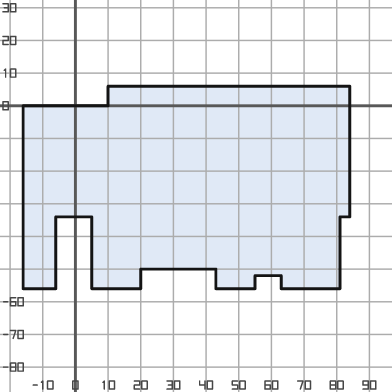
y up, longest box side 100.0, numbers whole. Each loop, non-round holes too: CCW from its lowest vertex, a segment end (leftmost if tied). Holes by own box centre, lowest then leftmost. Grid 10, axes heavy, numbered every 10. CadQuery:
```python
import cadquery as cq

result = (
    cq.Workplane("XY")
    .moveTo(-16.0, -56.0)
    .lineTo(-6.0, -56.0)
    .lineTo(-6.0, -34.0)
    .lineTo(5.0, -34.0)
    .lineTo(5.0, -56.0)
    .lineTo(20.0, -56.0)
    .lineTo(20.0, -50.0)
    .lineTo(43.0, -50.0)
    .lineTo(43.0, -56.0)
    .lineTo(55.0, -56.0)
    .lineTo(55.0, -52.0)
    .lineTo(63.0, -52.0)
    .lineTo(63.0, -56.0)
    .lineTo(81.0, -56.0)
    .lineTo(81.0, -34.0)
    .lineTo(84.0, -34.0)
    .lineTo(84.0, 6.0)
    .lineTo(10.0, 6.0)
    .lineTo(10.0, 0.0)
    .lineTo(-16.0, 0.0)
    .close()
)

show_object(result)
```